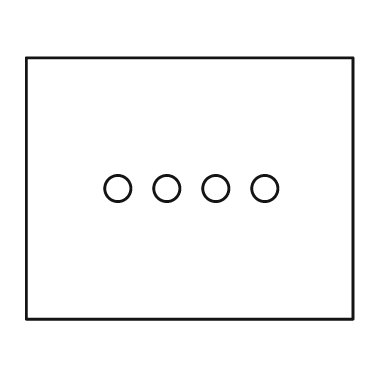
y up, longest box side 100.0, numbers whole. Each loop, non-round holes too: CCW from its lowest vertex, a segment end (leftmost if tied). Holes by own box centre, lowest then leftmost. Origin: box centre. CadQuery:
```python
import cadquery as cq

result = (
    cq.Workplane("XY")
    .moveTo(-50.0, -40.0)
    .lineTo(50.0, -40.0)
    .lineTo(50.0, 40.0)
    .lineTo(-50.0, 40.0)
    .close()
    .moveTo(-22.0, 0.0)
    .circle(4.0)
    .moveTo(-7.0, 0.0)
    .circle(4.0)
    .moveTo(8.0, 0.0)
    .circle(4.0)
    .moveTo(23.0, 0.0)
    .circle(4.0)
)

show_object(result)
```